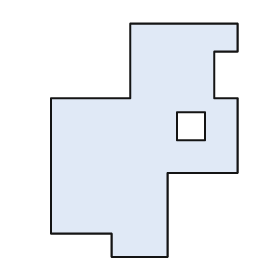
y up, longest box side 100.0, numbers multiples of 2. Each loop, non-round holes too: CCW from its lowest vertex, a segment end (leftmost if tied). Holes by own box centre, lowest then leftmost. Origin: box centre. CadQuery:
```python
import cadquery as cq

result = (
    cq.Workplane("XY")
    .moveTo(-14.0, -50.0)
    .lineTo(10.0, -50.0)
    .lineTo(10.0, -14.0)
    .lineTo(40.0, -14.0)
    .lineTo(40.0, 18.0)
    .lineTo(30.0, 18.0)
    .lineTo(30.0, 38.0)
    .lineTo(40.0, 38.0)
    .lineTo(40.0, 50.0)
    .lineTo(-6.0, 50.0)
    .lineTo(-6.0, 18.0)
    .lineTo(-40.0, 18.0)
    .lineTo(-40.0, -40.0)
    .lineTo(-14.0, -40.0)
    .close()
    .moveTo(14.0, 0.0)
    .lineTo(26.0, 0.0)
    .lineTo(26.0, 12.0)
    .lineTo(14.0, 12.0)
    .close()
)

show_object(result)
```